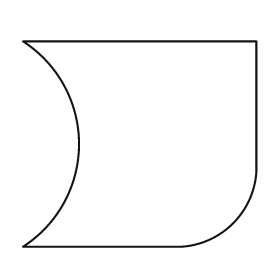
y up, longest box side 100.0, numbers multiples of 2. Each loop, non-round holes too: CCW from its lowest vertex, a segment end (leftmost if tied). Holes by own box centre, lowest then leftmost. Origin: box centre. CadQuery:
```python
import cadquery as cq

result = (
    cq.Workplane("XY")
    .moveTo(-50.0, -44.0)
    .lineTo(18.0, -44.0)
    .threePointArc((40.0, -34.0), (50.0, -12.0))
    .lineTo(50.0, 44.0)
    .lineTo(-50.0, 44.0)
    .threePointArc((-26.0, 0.0), (-50.0, -44.0))
    .close()
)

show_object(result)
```